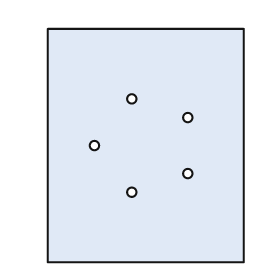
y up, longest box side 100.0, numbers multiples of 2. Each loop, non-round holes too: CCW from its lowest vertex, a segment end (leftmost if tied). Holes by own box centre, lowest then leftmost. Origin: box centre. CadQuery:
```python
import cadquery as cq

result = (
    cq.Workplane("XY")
    .moveTo(-42.0, -50.0)
    .lineTo(42.0, -50.0)
    .lineTo(42.0, 50.0)
    .lineTo(-42.0, 50.0)
    .close()
    .moveTo(-6.0, -20.0)
    .circle(2.0)
    .moveTo(18.0, -12.0)
    .circle(2.0)
    .moveTo(-22.0, 0.0)
    .circle(2.0)
    .moveTo(18.0, 12.0)
    .circle(2.0)
    .moveTo(-6.0, 20.0)
    .circle(2.0)
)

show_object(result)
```